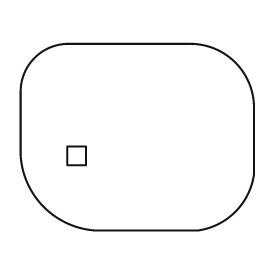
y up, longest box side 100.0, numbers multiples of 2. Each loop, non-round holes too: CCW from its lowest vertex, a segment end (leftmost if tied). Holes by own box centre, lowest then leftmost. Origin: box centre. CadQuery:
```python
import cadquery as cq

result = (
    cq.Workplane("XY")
    .moveTo(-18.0, -40.0)
    .lineTo(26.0, -40.0)
    .threePointArc((42.0, -32.0), (50.0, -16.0))
    .lineTo(50.0, 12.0)
    .threePointArc((42.0, 32.0), (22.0, 40.0))
    .lineTo(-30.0, 40.0)
    .threePointArc((-44.0, 34.0), (-50.0, 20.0))
    .lineTo(-50.0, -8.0)
    .threePointArc((-40.0, -30.0), (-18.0, -40.0))
    .close()
    .moveTo(-30.0, -12.0)
    .lineTo(-22.0, -12.0)
    .lineTo(-22.0, -4.0)
    .lineTo(-30.0, -4.0)
    .close()
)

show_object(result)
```